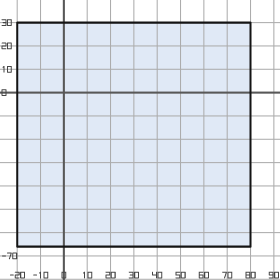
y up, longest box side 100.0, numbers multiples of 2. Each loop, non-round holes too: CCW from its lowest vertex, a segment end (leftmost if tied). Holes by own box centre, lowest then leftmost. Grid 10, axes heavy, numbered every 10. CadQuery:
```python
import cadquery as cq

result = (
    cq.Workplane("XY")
    .moveTo(-20.0, -66.0)
    .lineTo(80.0, -66.0)
    .lineTo(80.0, 30.0)
    .lineTo(-20.0, 30.0)
    .close()
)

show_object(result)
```